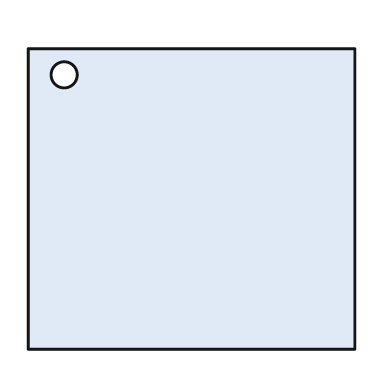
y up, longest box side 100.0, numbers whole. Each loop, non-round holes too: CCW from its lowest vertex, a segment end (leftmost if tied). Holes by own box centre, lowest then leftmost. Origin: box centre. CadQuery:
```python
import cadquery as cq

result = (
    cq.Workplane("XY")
    .moveTo(-50.0, -46.0)
    .lineTo(50.0, -46.0)
    .lineTo(50.0, 46.0)
    .lineTo(-50.0, 46.0)
    .close()
    .moveTo(-39.0, 38.0)
    .circle(4.0)
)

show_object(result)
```